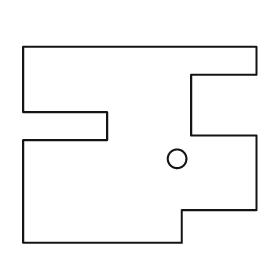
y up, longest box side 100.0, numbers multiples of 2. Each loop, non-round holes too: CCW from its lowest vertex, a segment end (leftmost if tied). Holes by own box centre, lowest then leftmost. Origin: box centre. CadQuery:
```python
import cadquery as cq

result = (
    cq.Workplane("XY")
    .moveTo(-50.0, -42.0)
    .lineTo(18.0, -42.0)
    .lineTo(18.0, -28.0)
    .lineTo(50.0, -28.0)
    .lineTo(50.0, 4.0)
    .lineTo(22.0, 4.0)
    .lineTo(22.0, 30.0)
    .lineTo(50.0, 30.0)
    .lineTo(50.0, 42.0)
    .lineTo(-50.0, 42.0)
    .lineTo(-50.0, 14.0)
    .lineTo(-14.0, 14.0)
    .lineTo(-14.0, 2.0)
    .lineTo(-50.0, 2.0)
    .close()
    .moveTo(16.0, -6.0)
    .circle(4.0)
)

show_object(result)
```